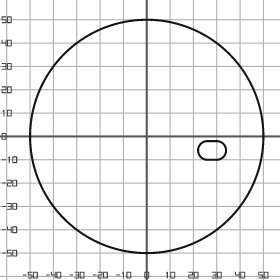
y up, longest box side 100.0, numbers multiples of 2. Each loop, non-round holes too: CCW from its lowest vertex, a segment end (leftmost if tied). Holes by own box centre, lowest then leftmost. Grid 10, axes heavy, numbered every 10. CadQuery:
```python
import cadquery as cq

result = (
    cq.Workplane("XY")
    .moveTo(0.0, 0.0)
    .circle(50.0)
    .moveTo(26.0, -10.0)
    .lineTo(30.0, -10.0)
    .threePointArc((34.0, -6.0), (30.0, -2.0))
    .lineTo(26.0, -2.0)
    .threePointArc((22.0, -6.0), (26.0, -10.0))
    .close()
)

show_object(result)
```